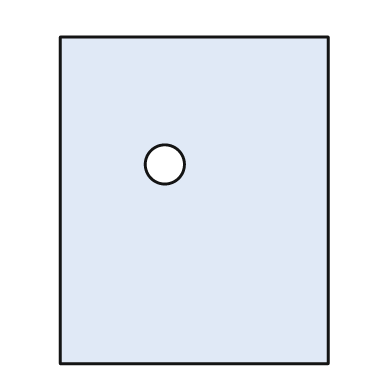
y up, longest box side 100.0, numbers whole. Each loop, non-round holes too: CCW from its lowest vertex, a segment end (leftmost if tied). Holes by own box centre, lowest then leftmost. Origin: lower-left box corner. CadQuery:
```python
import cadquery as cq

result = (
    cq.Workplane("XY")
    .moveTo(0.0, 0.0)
    .lineTo(82.0, 0.0)
    .lineTo(82.0, 100.0)
    .lineTo(0.0, 100.0)
    .close()
    .moveTo(32.0, 61.0)
    .circle(6.0)
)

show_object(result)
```